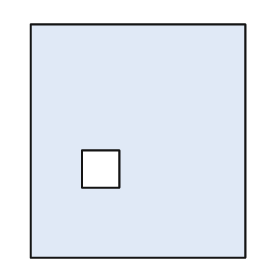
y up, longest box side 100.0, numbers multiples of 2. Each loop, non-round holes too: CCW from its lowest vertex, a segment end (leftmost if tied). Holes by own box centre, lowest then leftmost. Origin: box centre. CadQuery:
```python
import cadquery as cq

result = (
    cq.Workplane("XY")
    .moveTo(-46.0, -50.0)
    .lineTo(46.0, -50.0)
    .lineTo(46.0, 50.0)
    .lineTo(-46.0, 50.0)
    .close()
    .moveTo(-24.0, -20.0)
    .lineTo(-8.0, -20.0)
    .lineTo(-8.0, -4.0)
    .lineTo(-24.0, -4.0)
    .close()
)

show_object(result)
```